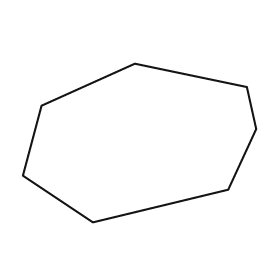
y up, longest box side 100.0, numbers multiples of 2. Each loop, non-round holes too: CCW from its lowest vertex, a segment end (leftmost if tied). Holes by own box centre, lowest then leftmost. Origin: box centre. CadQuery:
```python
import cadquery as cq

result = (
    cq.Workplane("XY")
    .moveTo(-20.0, -34.0)
    .lineTo(38.0, -20.0)
    .lineTo(50.0, 6.0)
    .lineTo(46.0, 24.0)
    .lineTo(-2.0, 34.0)
    .lineTo(-42.0, 16.0)
    .lineTo(-50.0, -14.0)
    .close()
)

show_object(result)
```